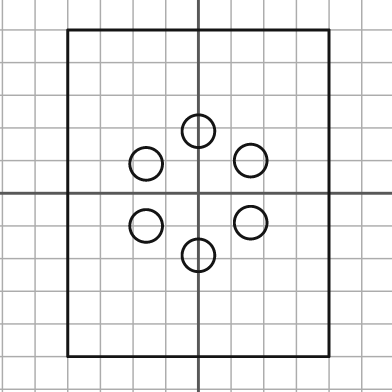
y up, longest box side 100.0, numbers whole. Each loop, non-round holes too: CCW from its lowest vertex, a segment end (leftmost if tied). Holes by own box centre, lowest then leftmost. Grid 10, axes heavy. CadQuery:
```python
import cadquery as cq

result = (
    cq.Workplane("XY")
    .moveTo(-40.0, -50.0)
    .lineTo(40.0, -50.0)
    .lineTo(40.0, 50.0)
    .lineTo(-40.0, 50.0)
    .close()
    .moveTo(0.0, -19.0)
    .circle(5.0)
    .moveTo(-16.0, -10.0)
    .circle(5.0)
    .moveTo(16.0, -9.0)
    .circle(5.0)
    .moveTo(-16.0, 9.0)
    .circle(5.0)
    .moveTo(16.0, 10.0)
    .circle(5.0)
    .moveTo(0.0, 19.0)
    .circle(5.0)
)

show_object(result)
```